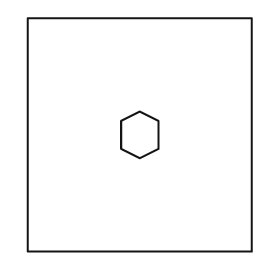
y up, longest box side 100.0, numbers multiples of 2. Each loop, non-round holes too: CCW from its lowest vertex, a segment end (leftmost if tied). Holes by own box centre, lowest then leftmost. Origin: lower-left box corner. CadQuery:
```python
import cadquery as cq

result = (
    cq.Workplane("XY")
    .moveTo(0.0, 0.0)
    .lineTo(96.0, 0.0)
    .lineTo(96.0, 100.0)
    .lineTo(0.0, 100.0)
    .close()
    .moveTo(48.0, 40.0)
    .lineTo(56.0, 44.0)
    .lineTo(56.0, 56.0)
    .lineTo(48.0, 60.0)
    .lineTo(40.0, 56.0)
    .lineTo(40.0, 44.0)
    .close()
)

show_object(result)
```